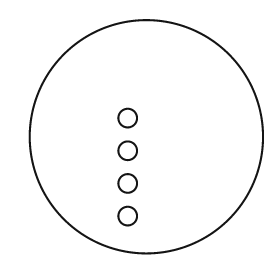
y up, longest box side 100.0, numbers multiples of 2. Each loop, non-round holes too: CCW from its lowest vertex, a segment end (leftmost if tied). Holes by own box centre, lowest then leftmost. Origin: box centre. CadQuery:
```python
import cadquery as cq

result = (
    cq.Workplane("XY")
    .moveTo(0.0, 0.0)
    .circle(50.0)
    .moveTo(-8.0, -34.0)
    .circle(4.0)
    .moveTo(-8.0, -20.0)
    .circle(4.0)
    .moveTo(-8.0, -6.0)
    .circle(4.0)
    .moveTo(-8.0, 8.0)
    .circle(4.0)
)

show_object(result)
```